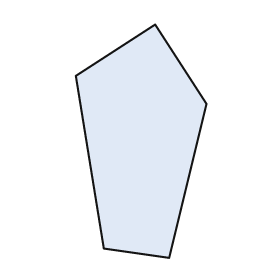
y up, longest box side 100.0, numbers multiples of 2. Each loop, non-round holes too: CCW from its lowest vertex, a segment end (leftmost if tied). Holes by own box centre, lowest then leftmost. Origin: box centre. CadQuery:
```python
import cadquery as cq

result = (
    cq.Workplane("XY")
    .moveTo(12.0, -50.0)
    .lineTo(28.0, 16.0)
    .lineTo(6.0, 50.0)
    .lineTo(-28.0, 28.0)
    .lineTo(-16.0, -46.0)
    .close()
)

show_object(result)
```